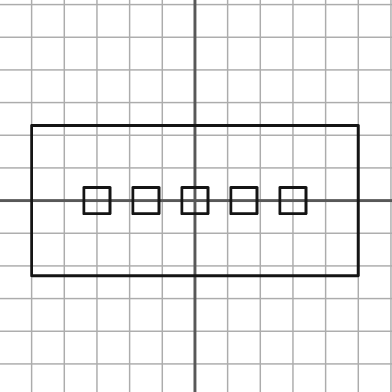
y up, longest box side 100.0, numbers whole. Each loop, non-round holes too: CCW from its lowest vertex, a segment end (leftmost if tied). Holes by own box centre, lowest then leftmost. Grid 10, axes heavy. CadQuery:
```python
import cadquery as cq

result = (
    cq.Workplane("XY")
    .moveTo(-50.0, -23.0)
    .lineTo(50.0, -23.0)
    .lineTo(50.0, 23.0)
    .lineTo(-50.0, 23.0)
    .close()
    .moveTo(-34.0, -4.0)
    .lineTo(-26.0, -4.0)
    .lineTo(-26.0, 4.0)
    .lineTo(-34.0, 4.0)
    .close()
    .moveTo(-19.0, -4.0)
    .lineTo(-11.0, -4.0)
    .lineTo(-11.0, 4.0)
    .lineTo(-19.0, 4.0)
    .close()
    .moveTo(-4.0, -4.0)
    .lineTo(4.0, -4.0)
    .lineTo(4.0, 4.0)
    .lineTo(-4.0, 4.0)
    .close()
    .moveTo(11.0, -4.0)
    .lineTo(19.0, -4.0)
    .lineTo(19.0, 4.0)
    .lineTo(11.0, 4.0)
    .close()
    .moveTo(26.0, -4.0)
    .lineTo(34.0, -4.0)
    .lineTo(34.0, 4.0)
    .lineTo(26.0, 4.0)
    .close()
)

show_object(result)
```